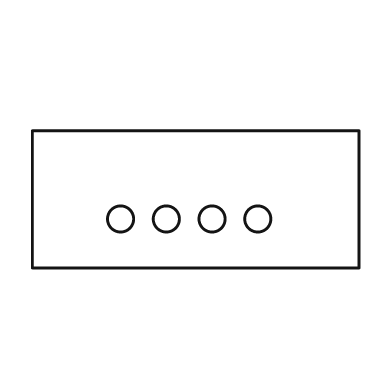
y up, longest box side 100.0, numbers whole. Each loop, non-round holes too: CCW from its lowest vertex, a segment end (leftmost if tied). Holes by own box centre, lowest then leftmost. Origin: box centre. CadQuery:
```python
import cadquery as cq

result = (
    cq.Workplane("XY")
    .moveTo(-50.0, -21.0)
    .lineTo(50.0, -21.0)
    .lineTo(50.0, 21.0)
    .lineTo(-50.0, 21.0)
    .close()
    .moveTo(-23.0, -6.0)
    .circle(4.0)
    .moveTo(-9.0, -6.0)
    .circle(4.0)
    .moveTo(5.0, -6.0)
    .circle(4.0)
    .moveTo(19.0, -6.0)
    .circle(4.0)
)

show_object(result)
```